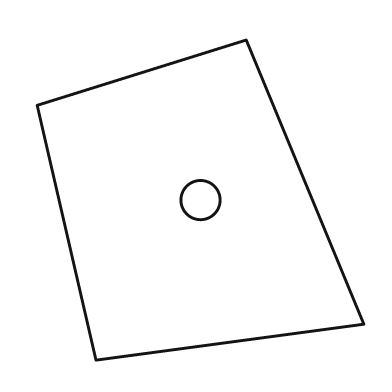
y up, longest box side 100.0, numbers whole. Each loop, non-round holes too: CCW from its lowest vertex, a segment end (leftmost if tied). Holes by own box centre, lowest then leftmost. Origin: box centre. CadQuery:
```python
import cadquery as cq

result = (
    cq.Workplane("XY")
    .moveTo(-32.0, -49.0)
    .lineTo(50.0, -38.0)
    .lineTo(14.0, 49.0)
    .lineTo(-50.0, 29.0)
    .close()
    .moveTo(0.0, 0.0)
    .circle(6.0)
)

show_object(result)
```